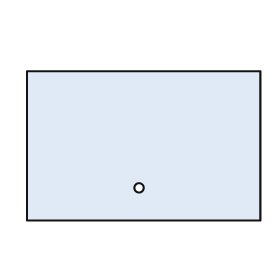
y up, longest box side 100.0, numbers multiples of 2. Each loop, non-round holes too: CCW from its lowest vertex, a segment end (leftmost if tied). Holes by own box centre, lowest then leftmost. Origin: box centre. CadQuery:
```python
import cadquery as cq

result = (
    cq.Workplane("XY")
    .moveTo(-50.0, -32.0)
    .lineTo(50.0, -32.0)
    .lineTo(50.0, 32.0)
    .lineTo(-50.0, 32.0)
    .close()
    .moveTo(-2.0, -18.0)
    .circle(2.0)
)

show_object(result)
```